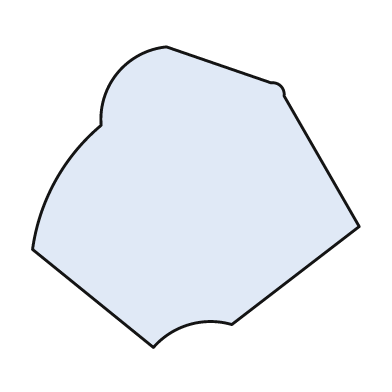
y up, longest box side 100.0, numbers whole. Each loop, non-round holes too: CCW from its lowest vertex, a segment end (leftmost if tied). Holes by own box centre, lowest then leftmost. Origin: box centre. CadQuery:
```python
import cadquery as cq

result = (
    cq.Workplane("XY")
    .moveTo(-13.0, -46.0)
    .threePointArc((-2.0, -39.0), (11.0, -39.0))
    .lineTo(50.0, -9.0)
    .lineTo(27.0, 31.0)
    .threePointArc((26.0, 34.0), (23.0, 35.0))
    .lineTo(-9.0, 46.0)
    .threePointArc((-24.0, 38.0), (-29.0, 22.0))
    .threePointArc((-43.0, 5.0), (-50.0, -16.0))
    .close()
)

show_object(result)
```